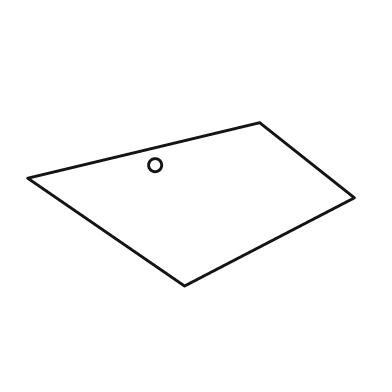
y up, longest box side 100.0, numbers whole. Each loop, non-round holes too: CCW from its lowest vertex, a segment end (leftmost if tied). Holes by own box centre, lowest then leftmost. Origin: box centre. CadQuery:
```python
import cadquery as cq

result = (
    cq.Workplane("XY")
    .moveTo(-2.0, -25.0)
    .lineTo(50.0, 2.0)
    .lineTo(21.0, 25.0)
    .lineTo(-50.0, 8.0)
    .close()
    .moveTo(-11.0, 12.0)
    .circle(2.0)
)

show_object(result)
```